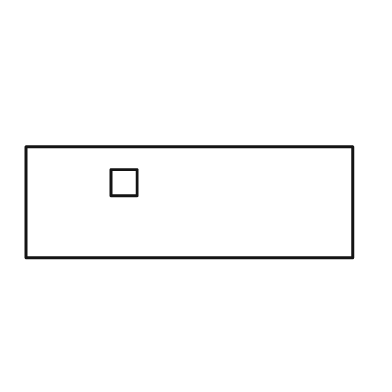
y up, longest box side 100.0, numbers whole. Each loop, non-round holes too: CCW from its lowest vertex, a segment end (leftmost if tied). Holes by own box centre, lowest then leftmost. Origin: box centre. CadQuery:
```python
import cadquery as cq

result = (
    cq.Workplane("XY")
    .moveTo(-50.0, -17.0)
    .lineTo(50.0, -17.0)
    .lineTo(50.0, 17.0)
    .lineTo(-50.0, 17.0)
    .close()
    .moveTo(-24.0, 2.0)
    .lineTo(-16.0, 2.0)
    .lineTo(-16.0, 10.0)
    .lineTo(-24.0, 10.0)
    .close()
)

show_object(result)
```